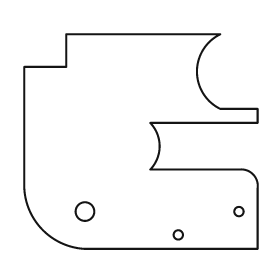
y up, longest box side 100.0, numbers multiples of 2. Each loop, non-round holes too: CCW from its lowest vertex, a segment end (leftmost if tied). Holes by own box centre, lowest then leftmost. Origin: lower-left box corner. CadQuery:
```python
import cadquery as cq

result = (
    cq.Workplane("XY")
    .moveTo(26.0, 0.0)
    .lineTo(100.0, 0.0)
    .lineTo(100.0, 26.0)
    .threePointArc((98.0, 32.0), (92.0, 34.0))
    .lineTo(54.0, 34.0)
    .threePointArc((58.0, 44.0), (54.0, 54.0))
    .lineTo(100.0, 54.0)
    .lineTo(100.0, 60.0)
    .lineTo(84.0, 60.0)
    .threePointArc((74.0, 76.0), (84.0, 92.0))
    .lineTo(18.0, 92.0)
    .lineTo(18.0, 78.0)
    .lineTo(0.0, 78.0)
    .lineTo(0.0, 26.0)
    .threePointArc((8.0, 8.0), (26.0, 0.0))
    .close()
    .moveTo(66.0, 6.0)
    .circle(2.0)
    .moveTo(26.0, 16.0)
    .circle(4.0)
    .moveTo(92.0, 16.0)
    .circle(2.0)
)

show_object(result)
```